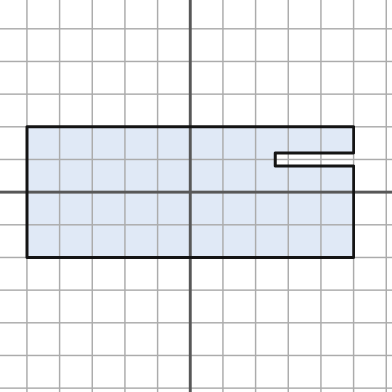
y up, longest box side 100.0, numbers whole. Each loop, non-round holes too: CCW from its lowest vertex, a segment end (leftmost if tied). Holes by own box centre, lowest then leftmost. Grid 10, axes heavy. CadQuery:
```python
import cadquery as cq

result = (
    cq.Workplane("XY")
    .moveTo(-50.0, -20.0)
    .lineTo(50.0, -20.0)
    .lineTo(50.0, 8.0)
    .lineTo(26.0, 8.0)
    .lineTo(26.0, 12.0)
    .lineTo(50.0, 12.0)
    .lineTo(50.0, 20.0)
    .lineTo(-50.0, 20.0)
    .close()
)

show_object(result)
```